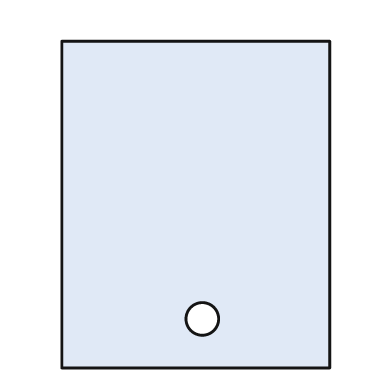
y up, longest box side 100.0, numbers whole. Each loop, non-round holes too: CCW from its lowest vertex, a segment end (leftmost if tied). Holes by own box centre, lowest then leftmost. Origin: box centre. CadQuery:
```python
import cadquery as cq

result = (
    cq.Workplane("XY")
    .moveTo(-41.0, -50.0)
    .lineTo(41.0, -50.0)
    .lineTo(41.0, 50.0)
    .lineTo(-41.0, 50.0)
    .close()
    .moveTo(2.0, -35.0)
    .circle(5.0)
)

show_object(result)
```